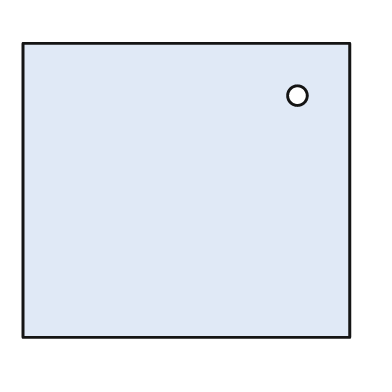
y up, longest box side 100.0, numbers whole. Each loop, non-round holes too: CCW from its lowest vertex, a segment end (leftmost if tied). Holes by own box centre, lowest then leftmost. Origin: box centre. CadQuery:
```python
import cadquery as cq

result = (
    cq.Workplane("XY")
    .moveTo(-50.0, -45.0)
    .lineTo(50.0, -45.0)
    .lineTo(50.0, 45.0)
    .lineTo(-50.0, 45.0)
    .close()
    .moveTo(34.0, 29.0)
    .circle(3.0)
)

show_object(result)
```